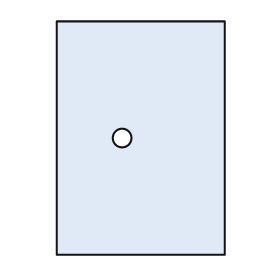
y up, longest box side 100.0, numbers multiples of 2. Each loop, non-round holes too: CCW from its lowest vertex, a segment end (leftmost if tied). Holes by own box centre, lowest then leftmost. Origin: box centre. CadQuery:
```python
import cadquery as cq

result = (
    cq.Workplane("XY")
    .moveTo(-36.0, -50.0)
    .lineTo(36.0, -50.0)
    .lineTo(36.0, 50.0)
    .lineTo(-36.0, 50.0)
    .close()
    .moveTo(-8.0, 0.0)
    .circle(4.0)
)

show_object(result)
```